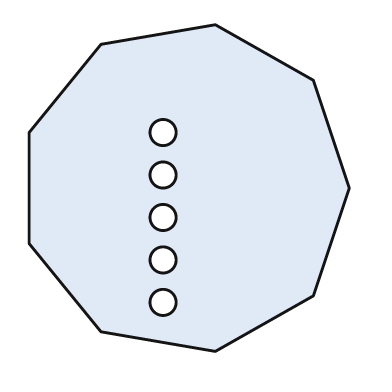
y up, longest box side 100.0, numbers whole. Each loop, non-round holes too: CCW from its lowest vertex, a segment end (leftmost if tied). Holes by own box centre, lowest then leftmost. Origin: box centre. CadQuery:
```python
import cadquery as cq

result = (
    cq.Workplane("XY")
    .moveTo(8.0, -50.0)
    .lineTo(38.0, -33.0)
    .lineTo(49.0, 0.0)
    .lineTo(38.0, 33.0)
    .lineTo(8.0, 50.0)
    .lineTo(-27.0, 44.0)
    .lineTo(-49.0, 17.0)
    .lineTo(-49.0, -17.0)
    .lineTo(-27.0, -44.0)
    .close()
    .moveTo(-8.0, -35.0)
    .circle(4.0)
    .moveTo(-8.0, -22.0)
    .circle(4.0)
    .moveTo(-8.0, -9.0)
    .circle(4.0)
    .moveTo(-8.0, 4.0)
    .circle(4.0)
    .moveTo(-8.0, 17.0)
    .circle(4.0)
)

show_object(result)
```